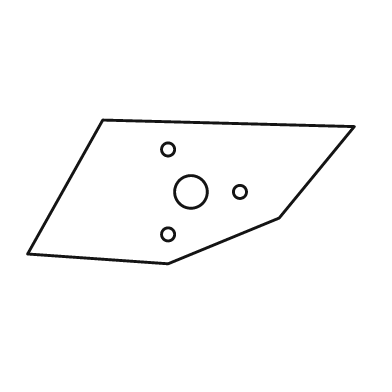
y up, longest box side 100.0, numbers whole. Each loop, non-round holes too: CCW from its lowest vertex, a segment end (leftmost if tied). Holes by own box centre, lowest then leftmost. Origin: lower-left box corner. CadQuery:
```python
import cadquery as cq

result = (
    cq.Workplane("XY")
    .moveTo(43.0, 0.0)
    .lineTo(77.0, 14.0)
    .lineTo(100.0, 42.0)
    .lineTo(23.0, 44.0)
    .lineTo(0.0, 3.0)
    .close()
    .moveTo(43.0, 9.0)
    .circle(2.0)
    .moveTo(50.0, 22.0)
    .circle(5.0)
    .moveTo(65.0, 22.0)
    .circle(2.0)
    .moveTo(43.0, 35.0)
    .circle(2.0)
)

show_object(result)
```